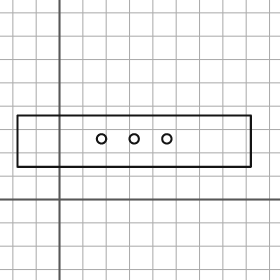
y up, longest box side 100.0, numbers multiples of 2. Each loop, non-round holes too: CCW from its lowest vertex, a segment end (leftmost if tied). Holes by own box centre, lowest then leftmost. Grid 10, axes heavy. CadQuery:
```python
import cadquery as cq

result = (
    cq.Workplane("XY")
    .moveTo(-18.0, 14.0)
    .lineTo(82.0, 14.0)
    .lineTo(82.0, 36.0)
    .lineTo(-18.0, 36.0)
    .close()
    .moveTo(18.0, 26.0)
    .circle(2.0)
    .moveTo(32.0, 26.0)
    .circle(2.0)
    .moveTo(46.0, 26.0)
    .circle(2.0)
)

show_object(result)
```